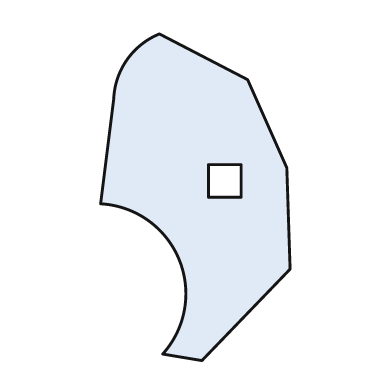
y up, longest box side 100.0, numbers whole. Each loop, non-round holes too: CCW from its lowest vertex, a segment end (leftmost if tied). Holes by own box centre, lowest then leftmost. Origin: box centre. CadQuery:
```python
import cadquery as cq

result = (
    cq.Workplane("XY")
    .moveTo(2.0, -50.0)
    .lineTo(29.0, -22.0)
    .lineTo(28.0, 9.0)
    .lineTo(16.0, 36.0)
    .lineTo(-11.0, 50.0)
    .threePointArc((-21.0, 42.0), (-25.0, 30.0))
    .lineTo(-29.0, -2.0)
    .threePointArc((-5.0, -19.0), (-10.0, -48.0))
    .close()
    .moveTo(4.0, 0.0)
    .lineTo(14.0, 0.0)
    .lineTo(14.0, 10.0)
    .lineTo(4.0, 10.0)
    .close()
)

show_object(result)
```